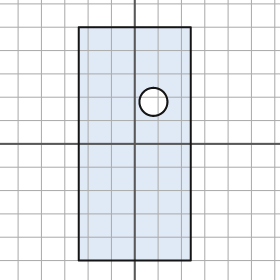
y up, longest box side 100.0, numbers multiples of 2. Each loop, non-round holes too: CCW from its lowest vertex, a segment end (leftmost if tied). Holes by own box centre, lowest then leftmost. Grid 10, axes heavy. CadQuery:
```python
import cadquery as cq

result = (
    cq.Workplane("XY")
    .moveTo(-24.0, -50.0)
    .lineTo(24.0, -50.0)
    .lineTo(24.0, 50.0)
    .lineTo(-24.0, 50.0)
    .close()
    .moveTo(8.0, 18.0)
    .circle(6.0)
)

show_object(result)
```